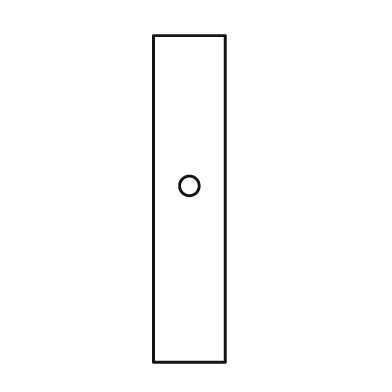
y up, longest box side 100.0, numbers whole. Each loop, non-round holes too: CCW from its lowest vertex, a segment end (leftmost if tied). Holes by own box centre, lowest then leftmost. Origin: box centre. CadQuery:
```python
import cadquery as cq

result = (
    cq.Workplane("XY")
    .moveTo(-11.0, -50.0)
    .lineTo(11.0, -50.0)
    .lineTo(11.0, 50.0)
    .lineTo(-11.0, 50.0)
    .close()
    .moveTo(0.0, 4.0)
    .circle(3.0)
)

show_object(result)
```